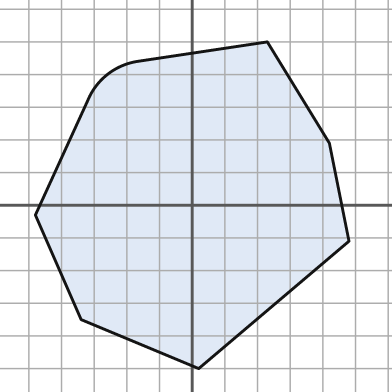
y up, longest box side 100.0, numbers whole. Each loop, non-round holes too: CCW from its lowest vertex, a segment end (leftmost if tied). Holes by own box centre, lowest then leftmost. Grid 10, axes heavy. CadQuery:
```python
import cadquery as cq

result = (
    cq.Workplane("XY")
    .moveTo(2.0, -50.0)
    .lineTo(48.0, -11.0)
    .lineTo(42.0, 19.0)
    .lineTo(23.0, 50.0)
    .lineTo(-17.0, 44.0)
    .threePointArc((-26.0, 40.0), (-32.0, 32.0))
    .lineTo(-48.0, -3.0)
    .lineTo(-34.0, -35.0)
    .close()
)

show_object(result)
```